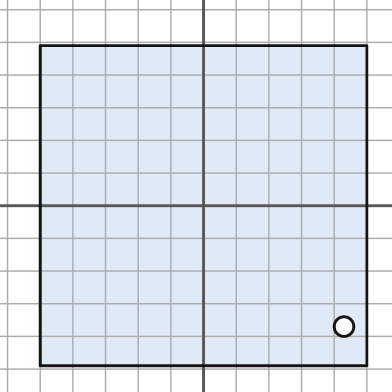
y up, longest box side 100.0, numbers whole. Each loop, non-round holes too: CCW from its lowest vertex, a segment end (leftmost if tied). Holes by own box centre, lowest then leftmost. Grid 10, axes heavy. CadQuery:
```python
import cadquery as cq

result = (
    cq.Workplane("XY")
    .moveTo(-50.0, -49.0)
    .lineTo(50.0, -49.0)
    .lineTo(50.0, 49.0)
    .lineTo(-50.0, 49.0)
    .close()
    .moveTo(43.0, -37.0)
    .circle(3.0)
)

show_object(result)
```